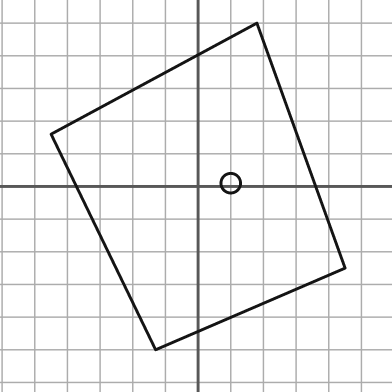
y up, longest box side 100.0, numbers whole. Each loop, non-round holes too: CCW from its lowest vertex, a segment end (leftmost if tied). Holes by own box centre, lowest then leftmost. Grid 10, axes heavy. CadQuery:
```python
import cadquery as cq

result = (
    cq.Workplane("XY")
    .moveTo(-13.0, -50.0)
    .lineTo(45.0, -25.0)
    .lineTo(18.0, 50.0)
    .lineTo(-45.0, 16.0)
    .close()
    .moveTo(10.0, 1.0)
    .circle(3.0)
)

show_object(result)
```